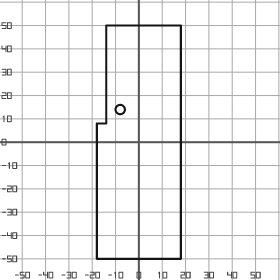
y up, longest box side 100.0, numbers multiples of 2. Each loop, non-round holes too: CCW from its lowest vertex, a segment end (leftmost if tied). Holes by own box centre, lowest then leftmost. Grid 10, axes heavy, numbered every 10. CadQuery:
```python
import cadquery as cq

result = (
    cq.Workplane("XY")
    .moveTo(-18.0, -50.0)
    .lineTo(18.0, -50.0)
    .lineTo(18.0, 50.0)
    .lineTo(-14.0, 50.0)
    .lineTo(-14.0, 8.0)
    .lineTo(-18.0, 8.0)
    .close()
    .moveTo(-8.0, 14.0)
    .circle(2.0)
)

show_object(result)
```